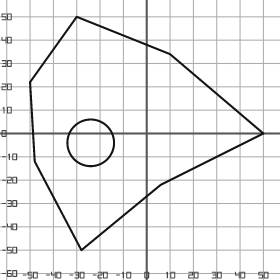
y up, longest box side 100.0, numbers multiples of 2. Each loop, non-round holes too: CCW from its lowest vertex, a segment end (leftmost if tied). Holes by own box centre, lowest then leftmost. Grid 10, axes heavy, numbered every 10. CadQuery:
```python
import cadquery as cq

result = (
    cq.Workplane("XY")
    .moveTo(-28.0, -50.0)
    .lineTo(6.0, -22.0)
    .lineTo(50.0, 0.0)
    .lineTo(10.0, 34.0)
    .lineTo(-30.0, 50.0)
    .lineTo(-50.0, 22.0)
    .lineTo(-48.0, -12.0)
    .close()
    .moveTo(-24.0, -4.0)
    .circle(10.0)
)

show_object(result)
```